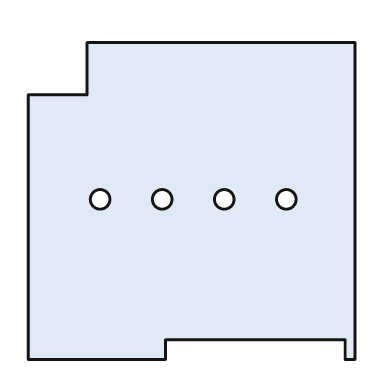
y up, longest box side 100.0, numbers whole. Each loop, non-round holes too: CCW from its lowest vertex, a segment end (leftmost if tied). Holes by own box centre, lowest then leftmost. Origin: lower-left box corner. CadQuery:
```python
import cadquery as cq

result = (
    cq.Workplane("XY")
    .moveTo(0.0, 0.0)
    .lineTo(42.0, 0.0)
    .lineTo(42.0, 6.0)
    .lineTo(97.0, 6.0)
    .lineTo(97.0, 0.0)
    .lineTo(100.0, 0.0)
    .lineTo(100.0, 97.0)
    .lineTo(18.0, 97.0)
    .lineTo(18.0, 81.0)
    .lineTo(0.0, 81.0)
    .close()
    .moveTo(22.0, 49.0)
    .circle(3.0)
    .moveTo(41.0, 49.0)
    .circle(3.0)
    .moveTo(60.0, 49.0)
    .circle(3.0)
    .moveTo(79.0, 49.0)
    .circle(3.0)
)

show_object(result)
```